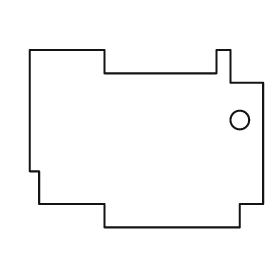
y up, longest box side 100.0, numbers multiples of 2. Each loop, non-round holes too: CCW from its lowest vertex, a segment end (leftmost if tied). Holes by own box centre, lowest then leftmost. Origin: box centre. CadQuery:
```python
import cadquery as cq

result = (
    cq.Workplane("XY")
    .moveTo(-18.0, -38.0)
    .lineTo(40.0, -38.0)
    .lineTo(40.0, -28.0)
    .lineTo(50.0, -28.0)
    .lineTo(50.0, 24.0)
    .lineTo(36.0, 24.0)
    .lineTo(36.0, 38.0)
    .lineTo(30.0, 38.0)
    .lineTo(30.0, 28.0)
    .lineTo(-18.0, 28.0)
    .lineTo(-18.0, 38.0)
    .lineTo(-50.0, 38.0)
    .lineTo(-50.0, -14.0)
    .lineTo(-46.0, -14.0)
    .lineTo(-46.0, -28.0)
    .lineTo(-18.0, -28.0)
    .close()
    .moveTo(40.0, 8.0)
    .circle(4.0)
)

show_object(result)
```